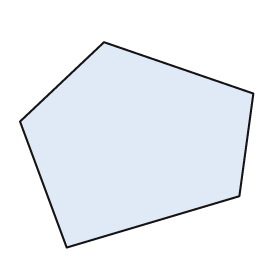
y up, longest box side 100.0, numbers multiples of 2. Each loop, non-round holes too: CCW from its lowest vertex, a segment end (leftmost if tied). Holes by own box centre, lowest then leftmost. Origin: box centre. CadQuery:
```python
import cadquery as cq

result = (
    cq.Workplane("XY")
    .moveTo(-30.0, -44.0)
    .lineTo(44.0, -22.0)
    .lineTo(50.0, 22.0)
    .lineTo(-14.0, 44.0)
    .lineTo(-50.0, 10.0)
    .close()
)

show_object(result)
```